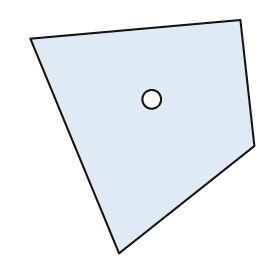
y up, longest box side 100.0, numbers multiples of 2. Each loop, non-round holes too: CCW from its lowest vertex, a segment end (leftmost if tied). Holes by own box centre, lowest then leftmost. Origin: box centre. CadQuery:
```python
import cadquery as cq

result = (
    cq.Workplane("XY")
    .moveTo(-10.0, -50.0)
    .lineTo(48.0, -4.0)
    .lineTo(42.0, 50.0)
    .lineTo(-48.0, 42.0)
    .close()
    .moveTo(4.0, 16.0)
    .circle(4.0)
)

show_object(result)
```